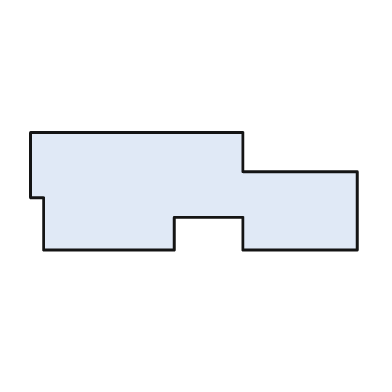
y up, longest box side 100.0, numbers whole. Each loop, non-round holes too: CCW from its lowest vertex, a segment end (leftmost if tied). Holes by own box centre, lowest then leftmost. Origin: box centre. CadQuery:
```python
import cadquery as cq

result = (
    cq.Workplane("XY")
    .moveTo(-46.0, -18.0)
    .lineTo(-6.0, -18.0)
    .lineTo(-6.0, -8.0)
    .lineTo(15.0, -8.0)
    .lineTo(15.0, -18.0)
    .lineTo(50.0, -18.0)
    .lineTo(50.0, 6.0)
    .lineTo(15.0, 6.0)
    .lineTo(15.0, 18.0)
    .lineTo(-50.0, 18.0)
    .lineTo(-50.0, -2.0)
    .lineTo(-46.0, -2.0)
    .close()
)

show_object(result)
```